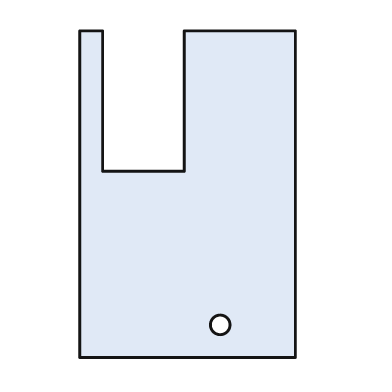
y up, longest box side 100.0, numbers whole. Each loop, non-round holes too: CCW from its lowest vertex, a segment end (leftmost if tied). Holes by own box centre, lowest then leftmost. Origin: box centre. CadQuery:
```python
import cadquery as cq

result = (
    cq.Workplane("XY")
    .moveTo(-33.0, -50.0)
    .lineTo(33.0, -50.0)
    .lineTo(33.0, 50.0)
    .lineTo(-1.0, 50.0)
    .lineTo(-1.0, 7.0)
    .lineTo(-26.0, 7.0)
    .lineTo(-26.0, 50.0)
    .lineTo(-33.0, 50.0)
    .close()
    .moveTo(10.0, -40.0)
    .circle(3.0)
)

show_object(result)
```